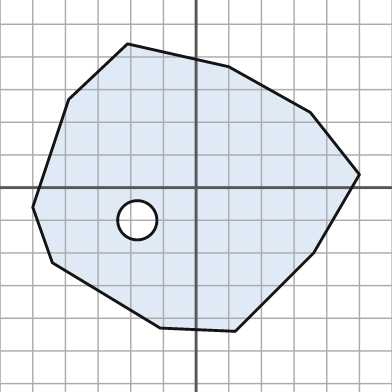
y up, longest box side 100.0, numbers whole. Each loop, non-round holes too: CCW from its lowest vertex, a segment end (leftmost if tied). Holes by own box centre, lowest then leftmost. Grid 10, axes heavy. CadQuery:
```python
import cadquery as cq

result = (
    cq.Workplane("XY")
    .moveTo(12.0, -44.0)
    .lineTo(36.0, -20.0)
    .lineTo(50.0, 4.0)
    .lineTo(35.0, 23.0)
    .lineTo(10.0, 37.0)
    .lineTo(-21.0, 44.0)
    .lineTo(-39.0, 27.0)
    .lineTo(-50.0, -6.0)
    .lineTo(-44.0, -23.0)
    .lineTo(-11.0, -43.0)
    .close()
    .moveTo(-18.0, -10.0)
    .circle(6.0)
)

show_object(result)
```